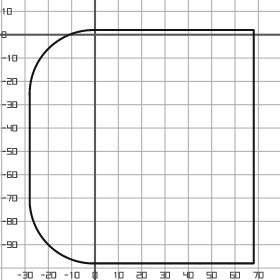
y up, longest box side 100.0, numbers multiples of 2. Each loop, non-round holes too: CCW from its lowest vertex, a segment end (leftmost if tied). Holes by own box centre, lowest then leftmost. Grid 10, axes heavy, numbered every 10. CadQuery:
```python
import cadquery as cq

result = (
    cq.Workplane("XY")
    .moveTo(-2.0, -98.0)
    .lineTo(68.0, -98.0)
    .lineTo(68.0, 2.0)
    .lineTo(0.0, 2.0)
    .threePointArc((-20.0, -6.0), (-28.0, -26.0))
    .lineTo(-28.0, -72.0)
    .threePointArc((-20.0, -90.0), (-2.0, -98.0))
    .close()
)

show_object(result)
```